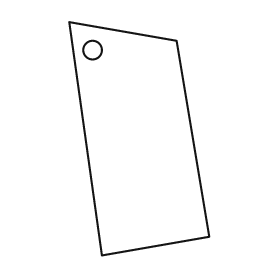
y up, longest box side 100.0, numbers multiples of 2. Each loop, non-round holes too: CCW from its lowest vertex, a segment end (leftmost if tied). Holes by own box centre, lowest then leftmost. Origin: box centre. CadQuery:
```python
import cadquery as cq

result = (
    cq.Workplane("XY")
    .moveTo(-16.0, -50.0)
    .lineTo(30.0, -42.0)
    .lineTo(16.0, 42.0)
    .lineTo(-30.0, 50.0)
    .close()
    .moveTo(-20.0, 38.0)
    .circle(4.0)
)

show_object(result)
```